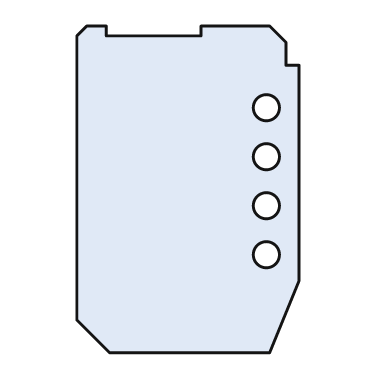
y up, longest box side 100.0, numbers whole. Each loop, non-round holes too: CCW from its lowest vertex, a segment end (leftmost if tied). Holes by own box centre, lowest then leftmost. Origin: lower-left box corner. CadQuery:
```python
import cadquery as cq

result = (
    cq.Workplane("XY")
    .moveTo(10.0, 0.0)
    .lineTo(59.0, 0.0)
    .lineTo(68.0, 22.0)
    .lineTo(68.0, 88.0)
    .lineTo(64.0, 88.0)
    .lineTo(64.0, 95.0)
    .lineTo(59.0, 100.0)
    .lineTo(38.0, 100.0)
    .lineTo(38.0, 97.0)
    .lineTo(9.0, 97.0)
    .lineTo(9.0, 100.0)
    .lineTo(3.0, 100.0)
    .lineTo(0.0, 97.0)
    .lineTo(0.0, 10.0)
    .close()
    .moveTo(58.0, 30.0)
    .circle(4.0)
    .moveTo(58.0, 45.0)
    .circle(4.0)
    .moveTo(58.0, 60.0)
    .circle(4.0)
    .moveTo(58.0, 75.0)
    .circle(4.0)
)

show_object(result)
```